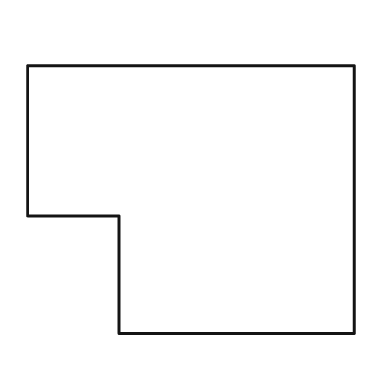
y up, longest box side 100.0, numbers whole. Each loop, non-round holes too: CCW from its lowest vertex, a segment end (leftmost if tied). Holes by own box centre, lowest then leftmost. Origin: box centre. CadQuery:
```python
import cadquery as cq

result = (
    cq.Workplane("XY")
    .moveTo(-22.0, -41.0)
    .lineTo(50.0, -41.0)
    .lineTo(50.0, 41.0)
    .lineTo(-50.0, 41.0)
    .lineTo(-50.0, -5.0)
    .lineTo(-22.0, -5.0)
    .close()
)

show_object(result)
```